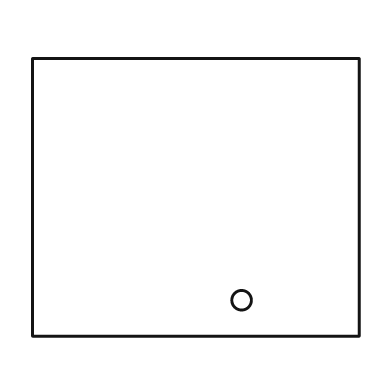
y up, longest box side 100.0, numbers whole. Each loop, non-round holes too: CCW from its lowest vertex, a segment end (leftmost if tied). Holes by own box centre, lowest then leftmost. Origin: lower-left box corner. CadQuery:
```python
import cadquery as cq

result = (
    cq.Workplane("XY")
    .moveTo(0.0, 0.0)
    .lineTo(100.0, 0.0)
    .lineTo(100.0, 85.0)
    .lineTo(0.0, 85.0)
    .close()
    .moveTo(64.0, 11.0)
    .circle(3.0)
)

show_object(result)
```